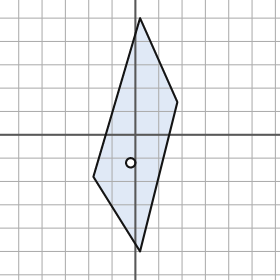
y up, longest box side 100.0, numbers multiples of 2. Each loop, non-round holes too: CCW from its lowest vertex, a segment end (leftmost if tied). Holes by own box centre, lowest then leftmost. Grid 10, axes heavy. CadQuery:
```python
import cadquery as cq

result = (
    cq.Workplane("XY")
    .moveTo(2.0, -50.0)
    .lineTo(18.0, 14.0)
    .lineTo(2.0, 50.0)
    .lineTo(-18.0, -18.0)
    .close()
    .moveTo(-2.0, -12.0)
    .circle(2.0)
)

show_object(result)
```